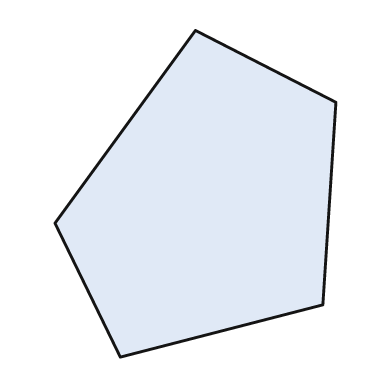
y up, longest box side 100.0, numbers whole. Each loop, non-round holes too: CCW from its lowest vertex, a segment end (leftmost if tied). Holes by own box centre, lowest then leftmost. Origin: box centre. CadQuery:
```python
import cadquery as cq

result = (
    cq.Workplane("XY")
    .moveTo(-23.0, -50.0)
    .lineTo(39.0, -34.0)
    .lineTo(43.0, 28.0)
    .lineTo(0.0, 50.0)
    .lineTo(-43.0, -9.0)
    .close()
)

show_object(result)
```